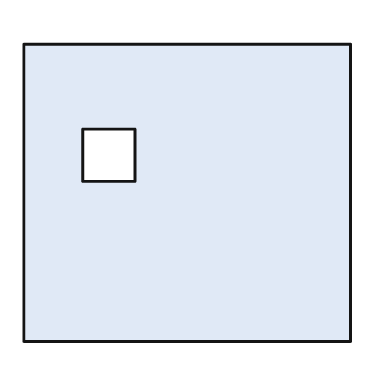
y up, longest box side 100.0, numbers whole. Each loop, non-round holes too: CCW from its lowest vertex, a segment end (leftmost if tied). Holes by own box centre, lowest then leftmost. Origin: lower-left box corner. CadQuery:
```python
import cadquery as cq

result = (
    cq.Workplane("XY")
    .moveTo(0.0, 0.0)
    .lineTo(100.0, 0.0)
    .lineTo(100.0, 91.0)
    .lineTo(0.0, 91.0)
    .close()
    .moveTo(18.0, 49.0)
    .lineTo(34.0, 49.0)
    .lineTo(34.0, 65.0)
    .lineTo(18.0, 65.0)
    .close()
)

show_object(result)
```